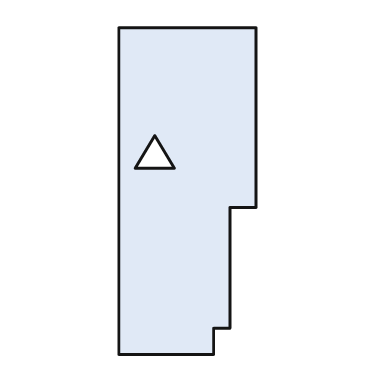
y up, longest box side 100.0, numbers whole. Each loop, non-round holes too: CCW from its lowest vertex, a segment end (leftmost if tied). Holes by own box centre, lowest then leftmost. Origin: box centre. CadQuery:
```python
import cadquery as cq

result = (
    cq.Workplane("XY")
    .moveTo(-21.0, -50.0)
    .lineTo(8.0, -50.0)
    .lineTo(8.0, -42.0)
    .lineTo(13.0, -42.0)
    .lineTo(13.0, -5.0)
    .lineTo(21.0, -5.0)
    .lineTo(21.0, 50.0)
    .lineTo(-21.0, 50.0)
    .close()
    .moveTo(-16.0, 7.0)
    .lineTo(-4.0, 7.0)
    .lineTo(-10.0, 17.0)
    .close()
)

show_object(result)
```